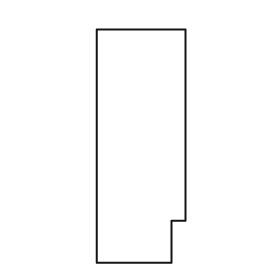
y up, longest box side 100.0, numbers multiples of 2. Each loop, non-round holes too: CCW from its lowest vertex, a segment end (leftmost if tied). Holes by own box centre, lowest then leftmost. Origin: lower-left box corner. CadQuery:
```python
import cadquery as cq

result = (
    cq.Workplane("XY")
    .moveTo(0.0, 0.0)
    .lineTo(32.0, 0.0)
    .lineTo(32.0, 18.0)
    .lineTo(38.0, 18.0)
    .lineTo(38.0, 100.0)
    .lineTo(0.0, 100.0)
    .close()
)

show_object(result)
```